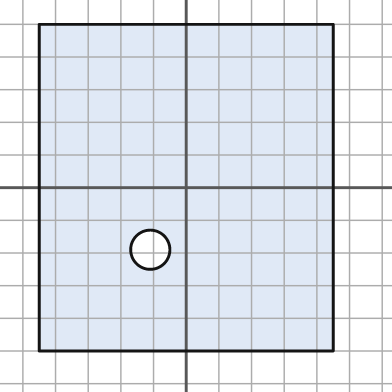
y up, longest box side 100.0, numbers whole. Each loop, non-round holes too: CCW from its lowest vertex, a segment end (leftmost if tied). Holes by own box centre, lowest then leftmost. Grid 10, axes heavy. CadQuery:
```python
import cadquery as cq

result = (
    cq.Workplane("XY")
    .moveTo(-45.0, -50.0)
    .lineTo(45.0, -50.0)
    .lineTo(45.0, 50.0)
    .lineTo(-45.0, 50.0)
    .close()
    .moveTo(-11.0, -19.0)
    .circle(6.0)
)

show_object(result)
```